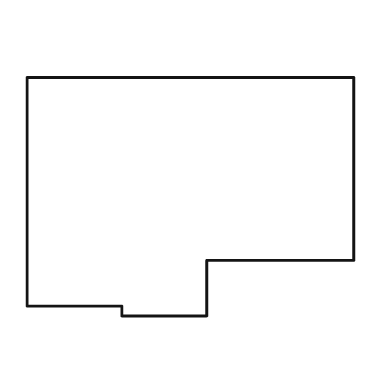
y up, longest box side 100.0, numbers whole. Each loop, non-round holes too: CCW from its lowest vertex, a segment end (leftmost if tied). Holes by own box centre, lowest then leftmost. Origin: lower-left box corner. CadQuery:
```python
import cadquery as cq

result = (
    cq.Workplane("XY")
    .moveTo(29.0, 0.0)
    .lineTo(55.0, 0.0)
    .lineTo(55.0, 17.0)
    .lineTo(100.0, 17.0)
    .lineTo(100.0, 73.0)
    .lineTo(0.0, 73.0)
    .lineTo(0.0, 3.0)
    .lineTo(29.0, 3.0)
    .close()
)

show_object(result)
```